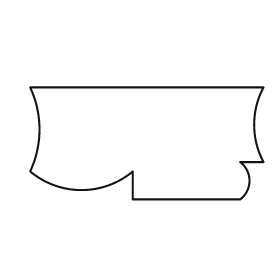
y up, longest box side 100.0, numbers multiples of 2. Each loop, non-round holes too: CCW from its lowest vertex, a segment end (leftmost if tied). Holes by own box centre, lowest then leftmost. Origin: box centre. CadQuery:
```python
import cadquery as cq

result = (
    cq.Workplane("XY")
    .moveTo(-6.0, -24.0)
    .lineTo(40.0, -24.0)
    .threePointArc((44.0, -16.0), (40.0, -8.0))
    .lineTo(50.0, -8.0)
    .threePointArc((46.0, 8.0), (50.0, 24.0))
    .lineTo(-50.0, 24.0)
    .threePointArc((-46.0, 6.0), (-50.0, -12.0))
    .threePointArc((-28.0, -20.0), (-6.0, -12.0))
    .close()
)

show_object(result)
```